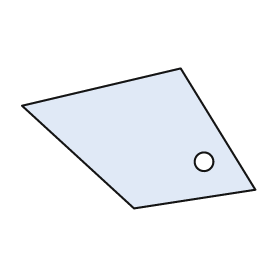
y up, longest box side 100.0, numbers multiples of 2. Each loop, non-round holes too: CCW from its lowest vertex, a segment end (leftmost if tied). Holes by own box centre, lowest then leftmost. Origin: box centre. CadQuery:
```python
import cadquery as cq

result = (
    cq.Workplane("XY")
    .moveTo(-2.0, -30.0)
    .lineTo(50.0, -22.0)
    .lineTo(18.0, 30.0)
    .lineTo(-50.0, 14.0)
    .close()
    .moveTo(28.0, -10.0)
    .circle(4.0)
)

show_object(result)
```